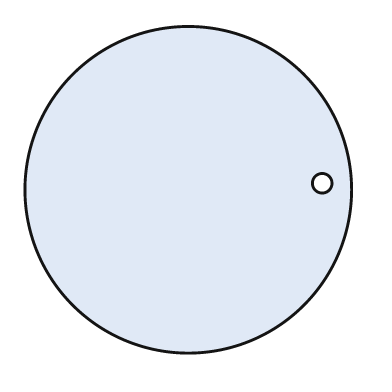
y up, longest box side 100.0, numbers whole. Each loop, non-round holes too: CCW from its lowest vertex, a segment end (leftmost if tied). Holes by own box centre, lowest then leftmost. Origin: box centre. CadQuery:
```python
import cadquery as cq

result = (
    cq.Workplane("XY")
    .moveTo(0.0, 0.0)
    .circle(50.0)
    .moveTo(41.0, 2.0)
    .circle(3.0)
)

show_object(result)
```